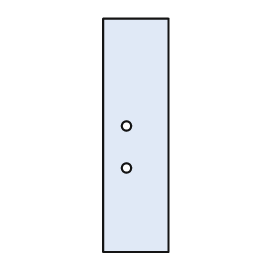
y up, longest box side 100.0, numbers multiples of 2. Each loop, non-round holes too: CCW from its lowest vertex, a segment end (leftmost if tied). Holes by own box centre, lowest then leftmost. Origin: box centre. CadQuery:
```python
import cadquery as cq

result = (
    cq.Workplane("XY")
    .moveTo(-14.0, -50.0)
    .lineTo(14.0, -50.0)
    .lineTo(14.0, 50.0)
    .lineTo(-14.0, 50.0)
    .close()
    .moveTo(-4.0, -14.0)
    .circle(2.0)
    .moveTo(-4.0, 4.0)
    .circle(2.0)
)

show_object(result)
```